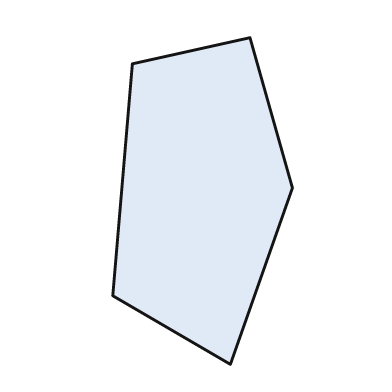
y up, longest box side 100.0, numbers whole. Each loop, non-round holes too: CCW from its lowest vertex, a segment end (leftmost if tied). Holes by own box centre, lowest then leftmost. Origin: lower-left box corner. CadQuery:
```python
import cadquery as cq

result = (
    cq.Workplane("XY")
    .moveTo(36.0, 0.0)
    .lineTo(55.0, 54.0)
    .lineTo(42.0, 100.0)
    .lineTo(6.0, 92.0)
    .lineTo(0.0, 21.0)
    .close()
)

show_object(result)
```